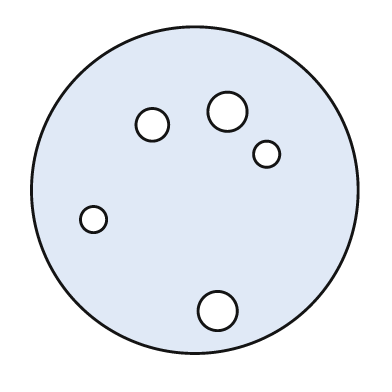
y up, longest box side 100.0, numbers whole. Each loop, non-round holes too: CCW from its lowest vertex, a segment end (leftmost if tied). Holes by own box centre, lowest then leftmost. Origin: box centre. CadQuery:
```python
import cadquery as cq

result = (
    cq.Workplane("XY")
    .moveTo(0.0, 0.0)
    .circle(50.0)
    .moveTo(7.0, -37.0)
    .circle(6.0)
    .moveTo(-31.0, -9.0)
    .circle(4.0)
    .moveTo(22.0, 11.0)
    .circle(4.0)
    .moveTo(-13.0, 20.0)
    .circle(5.0)
    .moveTo(10.0, 24.0)
    .circle(6.0)
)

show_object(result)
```